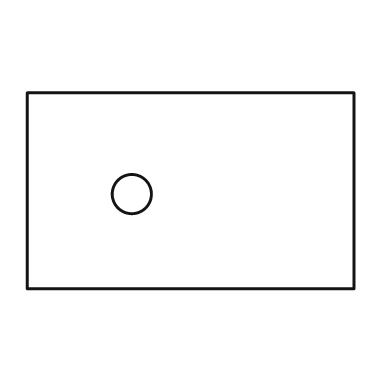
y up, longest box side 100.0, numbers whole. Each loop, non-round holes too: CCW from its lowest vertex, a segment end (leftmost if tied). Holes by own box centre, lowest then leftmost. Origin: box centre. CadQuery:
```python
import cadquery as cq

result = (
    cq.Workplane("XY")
    .moveTo(-50.0, -30.0)
    .lineTo(50.0, -30.0)
    .lineTo(50.0, 30.0)
    .lineTo(-50.0, 30.0)
    .close()
    .moveTo(-18.0, -1.0)
    .circle(6.0)
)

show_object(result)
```